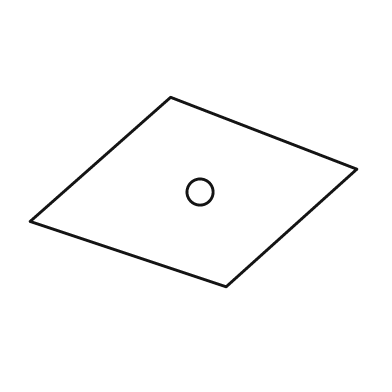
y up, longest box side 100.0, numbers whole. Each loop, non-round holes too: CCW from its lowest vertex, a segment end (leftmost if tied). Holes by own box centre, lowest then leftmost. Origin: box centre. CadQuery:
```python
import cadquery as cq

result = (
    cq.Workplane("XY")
    .moveTo(10.0, -29.0)
    .lineTo(50.0, 7.0)
    .lineTo(-7.0, 29.0)
    .lineTo(-50.0, -9.0)
    .close()
    .moveTo(2.0, 0.0)
    .circle(4.0)
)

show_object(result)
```